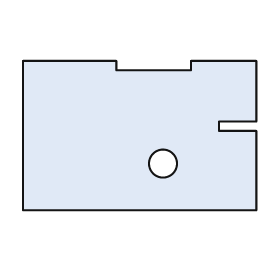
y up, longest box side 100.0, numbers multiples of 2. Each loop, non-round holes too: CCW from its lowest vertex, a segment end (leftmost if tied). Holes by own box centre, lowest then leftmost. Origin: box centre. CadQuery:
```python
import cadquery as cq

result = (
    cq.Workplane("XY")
    .moveTo(-50.0, -32.0)
    .lineTo(50.0, -32.0)
    .lineTo(50.0, 2.0)
    .lineTo(34.0, 2.0)
    .lineTo(34.0, 6.0)
    .lineTo(50.0, 6.0)
    .lineTo(50.0, 32.0)
    .lineTo(22.0, 32.0)
    .lineTo(22.0, 28.0)
    .lineTo(-10.0, 28.0)
    .lineTo(-10.0, 32.0)
    .lineTo(-50.0, 32.0)
    .close()
    .moveTo(10.0, -12.0)
    .circle(6.0)
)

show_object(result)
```